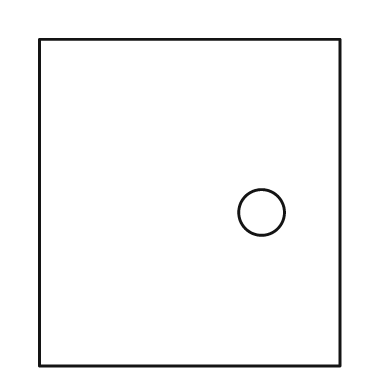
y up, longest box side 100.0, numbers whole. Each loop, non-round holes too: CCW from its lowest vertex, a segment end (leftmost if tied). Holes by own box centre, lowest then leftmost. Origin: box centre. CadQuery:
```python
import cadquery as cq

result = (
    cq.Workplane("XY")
    .moveTo(-46.0, -50.0)
    .lineTo(46.0, -50.0)
    .lineTo(46.0, 50.0)
    .lineTo(-46.0, 50.0)
    .close()
    .moveTo(22.0, -3.0)
    .circle(7.0)
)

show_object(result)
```